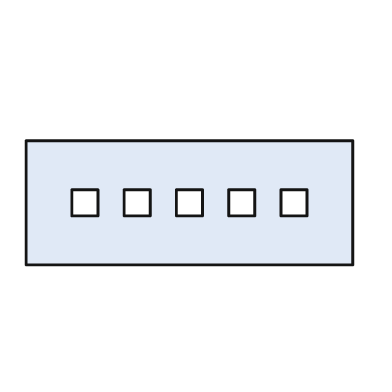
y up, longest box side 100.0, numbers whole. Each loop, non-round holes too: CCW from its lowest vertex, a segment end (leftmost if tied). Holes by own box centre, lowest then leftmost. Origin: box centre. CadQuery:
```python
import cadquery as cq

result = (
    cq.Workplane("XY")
    .moveTo(-50.0, -19.0)
    .lineTo(50.0, -19.0)
    .lineTo(50.0, 19.0)
    .lineTo(-50.0, 19.0)
    .close()
    .moveTo(-36.0, -4.0)
    .lineTo(-28.0, -4.0)
    .lineTo(-28.0, 4.0)
    .lineTo(-36.0, 4.0)
    .close()
    .moveTo(-20.0, -4.0)
    .lineTo(-12.0, -4.0)
    .lineTo(-12.0, 4.0)
    .lineTo(-20.0, 4.0)
    .close()
    .moveTo(-4.0, -4.0)
    .lineTo(4.0, -4.0)
    .lineTo(4.0, 4.0)
    .lineTo(-4.0, 4.0)
    .close()
    .moveTo(12.0, -4.0)
    .lineTo(20.0, -4.0)
    .lineTo(20.0, 4.0)
    .lineTo(12.0, 4.0)
    .close()
    .moveTo(28.0, -4.0)
    .lineTo(36.0, -4.0)
    .lineTo(36.0, 4.0)
    .lineTo(28.0, 4.0)
    .close()
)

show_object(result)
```